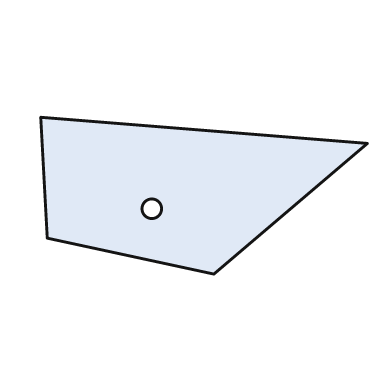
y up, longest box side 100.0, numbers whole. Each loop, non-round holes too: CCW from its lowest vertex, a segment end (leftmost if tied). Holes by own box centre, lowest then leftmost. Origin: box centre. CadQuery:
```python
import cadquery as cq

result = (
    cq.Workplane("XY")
    .moveTo(3.0, -24.0)
    .lineTo(50.0, 16.0)
    .lineTo(-50.0, 24.0)
    .lineTo(-48.0, -13.0)
    .close()
    .moveTo(-16.0, -4.0)
    .circle(3.0)
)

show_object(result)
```